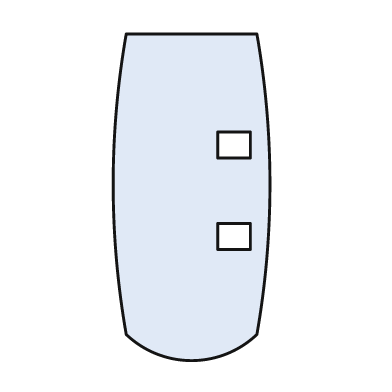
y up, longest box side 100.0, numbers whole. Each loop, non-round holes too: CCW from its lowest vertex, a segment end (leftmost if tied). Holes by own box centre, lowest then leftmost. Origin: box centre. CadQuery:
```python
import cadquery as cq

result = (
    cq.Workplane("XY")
    .moveTo(-20.0, -42.0)
    .threePointArc((0.0, -50.0), (20.0, -42.0))
    .threePointArc((24.0, 4.0), (20.0, 50.0))
    .lineTo(-20.0, 50.0)
    .threePointArc((-24.0, 4.0), (-20.0, -42.0))
    .close()
    .moveTo(8.0, -16.0)
    .lineTo(18.0, -16.0)
    .lineTo(18.0, -8.0)
    .lineTo(8.0, -8.0)
    .close()
    .moveTo(8.0, 12.0)
    .lineTo(18.0, 12.0)
    .lineTo(18.0, 20.0)
    .lineTo(8.0, 20.0)
    .close()
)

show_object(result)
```